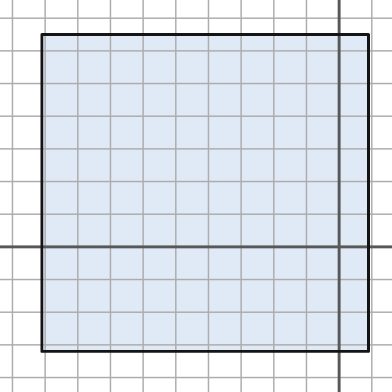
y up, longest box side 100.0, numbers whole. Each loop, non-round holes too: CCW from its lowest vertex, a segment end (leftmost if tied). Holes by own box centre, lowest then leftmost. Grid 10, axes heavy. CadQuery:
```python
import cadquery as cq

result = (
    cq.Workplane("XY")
    .moveTo(-91.0, -32.0)
    .lineTo(9.0, -32.0)
    .lineTo(9.0, 65.0)
    .lineTo(-91.0, 65.0)
    .close()
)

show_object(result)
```